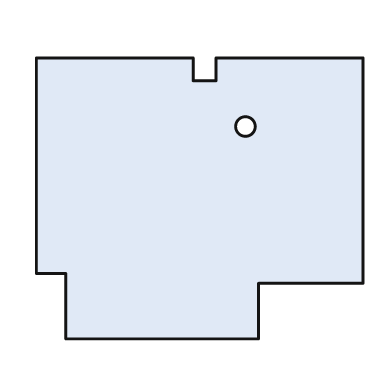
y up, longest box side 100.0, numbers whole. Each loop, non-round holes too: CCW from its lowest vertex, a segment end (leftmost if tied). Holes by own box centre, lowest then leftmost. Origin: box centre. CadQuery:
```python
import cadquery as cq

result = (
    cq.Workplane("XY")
    .moveTo(-41.0, -43.0)
    .lineTo(18.0, -43.0)
    .lineTo(18.0, -26.0)
    .lineTo(50.0, -26.0)
    .lineTo(50.0, 43.0)
    .lineTo(5.0, 43.0)
    .lineTo(5.0, 36.0)
    .lineTo(-2.0, 36.0)
    .lineTo(-2.0, 43.0)
    .lineTo(-50.0, 43.0)
    .lineTo(-50.0, -23.0)
    .lineTo(-41.0, -23.0)
    .close()
    .moveTo(14.0, 22.0)
    .circle(3.0)
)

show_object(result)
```